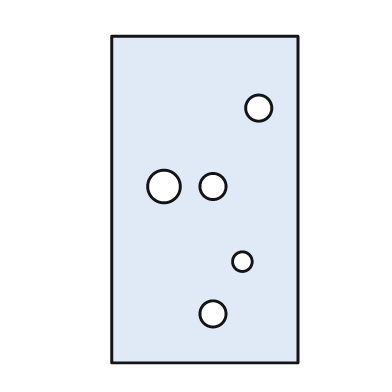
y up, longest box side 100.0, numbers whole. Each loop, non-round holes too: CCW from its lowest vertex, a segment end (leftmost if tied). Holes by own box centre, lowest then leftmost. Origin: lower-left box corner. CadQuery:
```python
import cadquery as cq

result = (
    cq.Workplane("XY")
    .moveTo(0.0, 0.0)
    .lineTo(57.0, 0.0)
    .lineTo(57.0, 100.0)
    .lineTo(0.0, 100.0)
    .close()
    .moveTo(31.0, 15.0)
    .circle(4.0)
    .moveTo(40.0, 31.0)
    .circle(3.0)
    .moveTo(16.0, 54.0)
    .circle(5.0)
    .moveTo(31.0, 54.0)
    .circle(4.0)
    .moveTo(45.0, 78.0)
    .circle(4.0)
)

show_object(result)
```